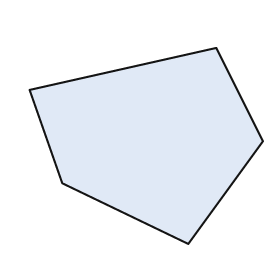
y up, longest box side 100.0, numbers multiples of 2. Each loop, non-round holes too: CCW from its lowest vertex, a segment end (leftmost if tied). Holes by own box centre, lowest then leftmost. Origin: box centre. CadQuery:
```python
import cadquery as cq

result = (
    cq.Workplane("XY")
    .moveTo(18.0, -42.0)
    .lineTo(50.0, 2.0)
    .lineTo(30.0, 42.0)
    .lineTo(-50.0, 24.0)
    .lineTo(-36.0, -16.0)
    .close()
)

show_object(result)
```